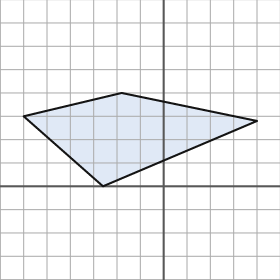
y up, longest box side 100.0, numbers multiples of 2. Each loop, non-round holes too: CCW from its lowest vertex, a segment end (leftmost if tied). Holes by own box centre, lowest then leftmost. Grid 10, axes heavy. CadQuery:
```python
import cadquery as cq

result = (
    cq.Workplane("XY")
    .moveTo(-26.0, 0.0)
    .lineTo(40.0, 28.0)
    .lineTo(-18.0, 40.0)
    .lineTo(-60.0, 30.0)
    .close()
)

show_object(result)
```